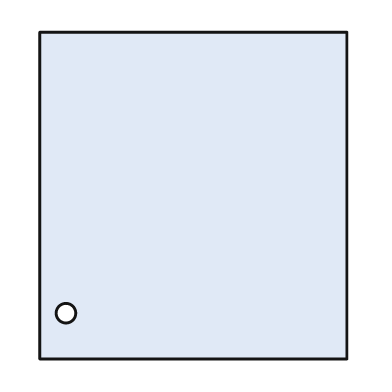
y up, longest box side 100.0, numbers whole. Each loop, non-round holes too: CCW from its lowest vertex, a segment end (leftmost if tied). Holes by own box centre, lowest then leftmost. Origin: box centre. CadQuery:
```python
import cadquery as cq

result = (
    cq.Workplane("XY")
    .moveTo(-47.0, -50.0)
    .lineTo(47.0, -50.0)
    .lineTo(47.0, 50.0)
    .lineTo(-47.0, 50.0)
    .close()
    .moveTo(-39.0, -36.0)
    .circle(3.0)
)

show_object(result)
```